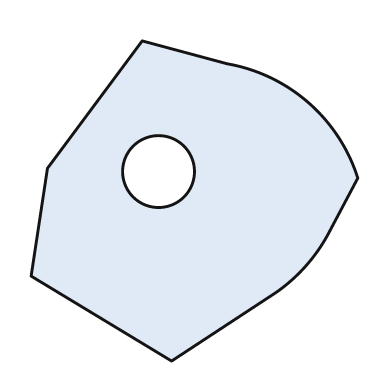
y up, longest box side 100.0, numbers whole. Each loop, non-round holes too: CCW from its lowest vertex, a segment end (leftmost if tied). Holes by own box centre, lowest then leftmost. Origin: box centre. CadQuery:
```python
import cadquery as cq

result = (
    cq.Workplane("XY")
    .moveTo(-7.0, -49.0)
    .lineTo(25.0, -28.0)
    .threePointArc((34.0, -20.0), (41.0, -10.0))
    .lineTo(50.0, 7.0)
    .threePointArc((35.0, 30.0), (10.0, 42.0))
    .lineTo(-16.0, 49.0)
    .lineTo(-45.0, 10.0)
    .lineTo(-50.0, -23.0)
    .close()
    .moveTo(-11.0, 9.0)
    .circle(11.0)
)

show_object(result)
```